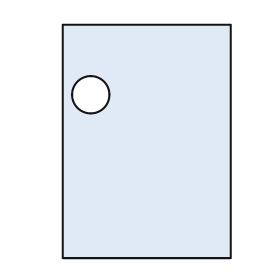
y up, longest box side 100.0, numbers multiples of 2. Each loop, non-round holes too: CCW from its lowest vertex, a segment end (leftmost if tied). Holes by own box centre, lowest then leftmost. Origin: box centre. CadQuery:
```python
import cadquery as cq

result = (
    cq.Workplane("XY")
    .moveTo(-36.0, -50.0)
    .lineTo(36.0, -50.0)
    .lineTo(36.0, 50.0)
    .lineTo(-36.0, 50.0)
    .close()
    .moveTo(-24.0, 20.0)
    .circle(8.0)
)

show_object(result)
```